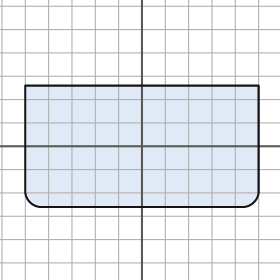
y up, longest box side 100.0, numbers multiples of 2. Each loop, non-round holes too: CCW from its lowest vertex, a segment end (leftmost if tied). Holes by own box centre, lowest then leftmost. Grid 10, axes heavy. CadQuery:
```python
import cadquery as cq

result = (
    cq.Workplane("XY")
    .moveTo(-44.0, -26.0)
    .lineTo(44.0, -26.0)
    .threePointArc((48.0, -24.0), (50.0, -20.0))
    .lineTo(50.0, 26.0)
    .lineTo(-50.0, 26.0)
    .lineTo(-50.0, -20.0)
    .threePointArc((-48.0, -24.0), (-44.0, -26.0))
    .close()
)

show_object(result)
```